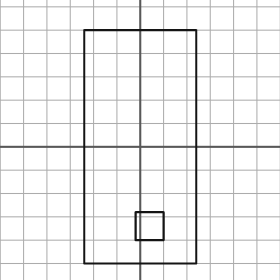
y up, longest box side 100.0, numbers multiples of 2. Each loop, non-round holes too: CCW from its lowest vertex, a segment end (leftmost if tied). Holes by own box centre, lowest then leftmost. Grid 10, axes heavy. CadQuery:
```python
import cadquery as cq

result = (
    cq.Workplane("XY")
    .moveTo(-24.0, -50.0)
    .lineTo(24.0, -50.0)
    .lineTo(24.0, 50.0)
    .lineTo(-24.0, 50.0)
    .close()
    .moveTo(-2.0, -40.0)
    .lineTo(10.0, -40.0)
    .lineTo(10.0, -28.0)
    .lineTo(-2.0, -28.0)
    .close()
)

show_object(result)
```